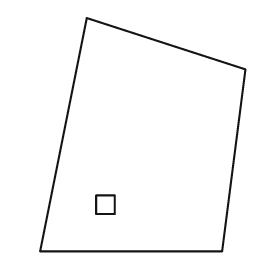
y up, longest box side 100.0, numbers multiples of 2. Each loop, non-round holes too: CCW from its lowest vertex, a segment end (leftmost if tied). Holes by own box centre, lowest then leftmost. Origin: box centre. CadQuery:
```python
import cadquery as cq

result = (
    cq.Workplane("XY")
    .moveTo(-44.0, -50.0)
    .lineTo(34.0, -50.0)
    .lineTo(44.0, 28.0)
    .lineTo(-24.0, 50.0)
    .close()
    .moveTo(-20.0, -34.0)
    .lineTo(-12.0, -34.0)
    .lineTo(-12.0, -26.0)
    .lineTo(-20.0, -26.0)
    .close()
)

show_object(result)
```